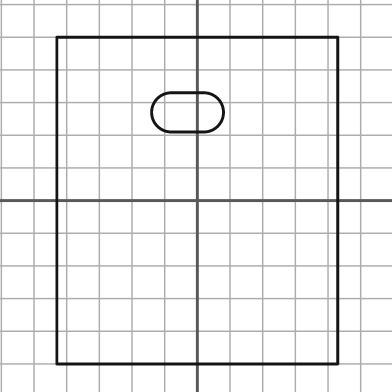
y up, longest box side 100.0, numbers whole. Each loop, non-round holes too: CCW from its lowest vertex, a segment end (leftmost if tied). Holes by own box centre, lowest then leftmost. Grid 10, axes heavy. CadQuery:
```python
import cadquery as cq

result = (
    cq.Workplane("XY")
    .moveTo(-43.0, -50.0)
    .lineTo(43.0, -50.0)
    .lineTo(43.0, 50.0)
    .lineTo(-43.0, 50.0)
    .close()
    .moveTo(-8.0, 21.0)
    .lineTo(2.0, 21.0)
    .threePointArc((8.0, 27.0), (2.0, 33.0))
    .lineTo(-8.0, 33.0)
    .threePointArc((-14.0, 27.0), (-8.0, 21.0))
    .close()
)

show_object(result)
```